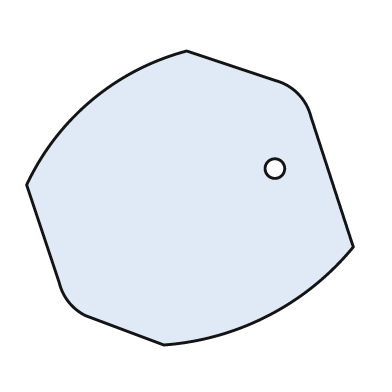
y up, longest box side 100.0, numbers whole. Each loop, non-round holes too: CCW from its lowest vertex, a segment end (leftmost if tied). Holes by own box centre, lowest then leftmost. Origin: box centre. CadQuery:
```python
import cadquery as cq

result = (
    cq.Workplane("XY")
    .moveTo(-8.0, -45.0)
    .threePointArc((24.0, -36.0), (50.0, -15.0))
    .lineTo(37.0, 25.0)
    .threePointArc((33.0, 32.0), (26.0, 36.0))
    .lineTo(-1.0, 45.0)
    .threePointArc((-30.0, 30.0), (-50.0, 4.0))
    .lineTo(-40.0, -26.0)
    .threePointArc((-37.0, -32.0), (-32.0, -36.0))
    .close()
    .moveTo(26.0, 9.0)
    .circle(3.0)
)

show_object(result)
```